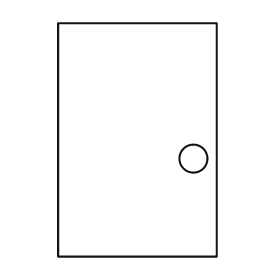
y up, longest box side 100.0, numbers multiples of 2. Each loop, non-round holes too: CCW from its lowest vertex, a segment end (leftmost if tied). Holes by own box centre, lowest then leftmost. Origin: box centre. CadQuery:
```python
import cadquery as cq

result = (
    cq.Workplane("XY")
    .moveTo(-34.0, -50.0)
    .lineTo(34.0, -50.0)
    .lineTo(34.0, 50.0)
    .lineTo(-34.0, 50.0)
    .close()
    .moveTo(24.0, -8.0)
    .circle(6.0)
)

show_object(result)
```